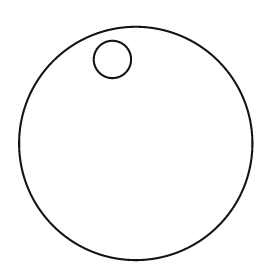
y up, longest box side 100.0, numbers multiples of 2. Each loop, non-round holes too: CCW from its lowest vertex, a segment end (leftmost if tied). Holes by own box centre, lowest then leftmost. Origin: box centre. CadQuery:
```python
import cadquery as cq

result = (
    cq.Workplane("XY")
    .moveTo(0.0, 0.0)
    .circle(50.0)
    .moveTo(-10.0, 36.0)
    .circle(8.0)
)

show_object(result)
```